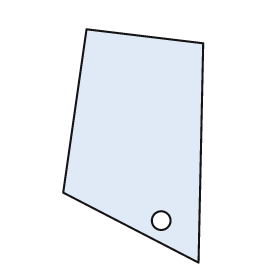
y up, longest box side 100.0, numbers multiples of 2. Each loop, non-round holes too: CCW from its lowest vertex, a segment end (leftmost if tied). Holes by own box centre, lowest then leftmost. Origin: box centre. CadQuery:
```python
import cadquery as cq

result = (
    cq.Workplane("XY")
    .moveTo(28.0, -50.0)
    .lineTo(30.0, 44.0)
    .lineTo(-20.0, 50.0)
    .lineTo(-30.0, -20.0)
    .close()
    .moveTo(12.0, -32.0)
    .circle(4.0)
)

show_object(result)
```